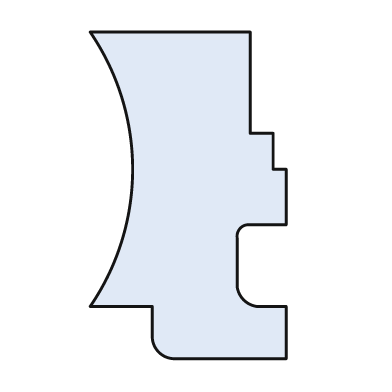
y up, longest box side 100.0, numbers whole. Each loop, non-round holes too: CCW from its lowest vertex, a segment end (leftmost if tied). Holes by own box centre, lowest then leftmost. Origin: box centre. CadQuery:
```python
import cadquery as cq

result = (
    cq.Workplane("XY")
    .moveTo(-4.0, -50.0)
    .lineTo(30.0, -50.0)
    .lineTo(30.0, -34.0)
    .lineTo(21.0, -34.0)
    .threePointArc((17.0, -32.0), (15.0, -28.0))
    .lineTo(15.0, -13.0)
    .threePointArc((16.0, -10.0), (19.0, -9.0))
    .lineTo(30.0, -9.0)
    .lineTo(30.0, 8.0)
    .lineTo(26.0, 8.0)
    .lineTo(26.0, 19.0)
    .lineTo(19.0, 19.0)
    .lineTo(19.0, 50.0)
    .lineTo(-30.0, 50.0)
    .threePointArc((-17.0, 8.0), (-30.0, -34.0))
    .lineTo(-11.0, -34.0)
    .lineTo(-11.0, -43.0)
    .threePointArc((-9.0, -48.0), (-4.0, -50.0))
    .close()
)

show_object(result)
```